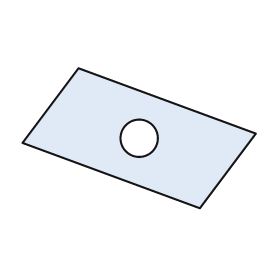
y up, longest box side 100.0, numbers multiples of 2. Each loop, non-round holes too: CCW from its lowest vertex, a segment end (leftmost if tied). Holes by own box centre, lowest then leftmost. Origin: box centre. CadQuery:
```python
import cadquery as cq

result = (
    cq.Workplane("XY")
    .moveTo(26.0, -30.0)
    .lineTo(50.0, 2.0)
    .lineTo(-26.0, 30.0)
    .lineTo(-50.0, -2.0)
    .close()
    .moveTo(0.0, 0.0)
    .circle(8.0)
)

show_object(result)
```